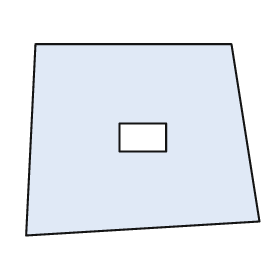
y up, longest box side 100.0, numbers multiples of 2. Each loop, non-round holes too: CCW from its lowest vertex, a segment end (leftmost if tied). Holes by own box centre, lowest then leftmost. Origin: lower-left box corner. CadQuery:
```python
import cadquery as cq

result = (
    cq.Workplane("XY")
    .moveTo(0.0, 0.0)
    .lineTo(100.0, 6.0)
    .lineTo(88.0, 82.0)
    .lineTo(4.0, 82.0)
    .close()
    .moveTo(40.0, 36.0)
    .lineTo(60.0, 36.0)
    .lineTo(60.0, 48.0)
    .lineTo(40.0, 48.0)
    .close()
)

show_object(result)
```